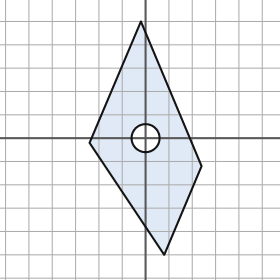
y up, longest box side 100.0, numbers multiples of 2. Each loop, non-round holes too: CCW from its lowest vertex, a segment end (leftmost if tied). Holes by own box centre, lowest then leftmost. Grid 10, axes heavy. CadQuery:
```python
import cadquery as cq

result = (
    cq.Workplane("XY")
    .moveTo(8.0, -50.0)
    .lineTo(24.0, -12.0)
    .lineTo(-2.0, 50.0)
    .lineTo(-24.0, -2.0)
    .close()
    .moveTo(0.0, 0.0)
    .circle(6.0)
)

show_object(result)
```